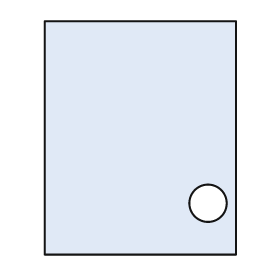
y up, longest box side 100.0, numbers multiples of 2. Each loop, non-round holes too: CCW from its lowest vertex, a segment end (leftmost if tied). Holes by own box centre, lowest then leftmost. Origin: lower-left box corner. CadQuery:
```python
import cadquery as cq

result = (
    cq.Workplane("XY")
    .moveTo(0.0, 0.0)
    .lineTo(82.0, 0.0)
    .lineTo(82.0, 100.0)
    .lineTo(0.0, 100.0)
    .close()
    .moveTo(70.0, 22.0)
    .circle(8.0)
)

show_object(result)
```